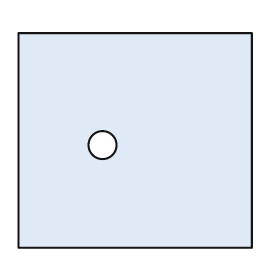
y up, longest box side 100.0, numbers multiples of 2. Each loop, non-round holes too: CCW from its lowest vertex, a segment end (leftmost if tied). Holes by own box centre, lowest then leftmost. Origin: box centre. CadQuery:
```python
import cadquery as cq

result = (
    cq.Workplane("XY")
    .moveTo(-50.0, -46.0)
    .lineTo(50.0, -46.0)
    .lineTo(50.0, 46.0)
    .lineTo(-50.0, 46.0)
    .close()
    .moveTo(-14.0, -2.0)
    .circle(6.0)
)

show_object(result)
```